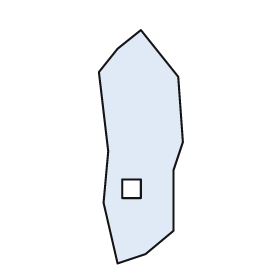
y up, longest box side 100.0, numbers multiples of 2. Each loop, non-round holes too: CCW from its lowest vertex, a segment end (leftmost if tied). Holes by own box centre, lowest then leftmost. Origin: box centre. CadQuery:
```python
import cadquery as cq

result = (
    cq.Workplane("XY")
    .moveTo(-10.0, -50.0)
    .lineTo(2.0, -46.0)
    .lineTo(14.0, -36.0)
    .lineTo(14.0, -10.0)
    .lineTo(18.0, 2.0)
    .lineTo(16.0, 30.0)
    .lineTo(0.0, 50.0)
    .lineTo(-10.0, 42.0)
    .lineTo(-18.0, 32.0)
    .lineTo(-14.0, -2.0)
    .lineTo(-16.0, -24.0)
    .close()
    .moveTo(-8.0, -22.0)
    .lineTo(0.0, -22.0)
    .lineTo(0.0, -14.0)
    .lineTo(-8.0, -14.0)
    .close()
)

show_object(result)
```